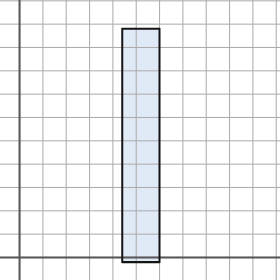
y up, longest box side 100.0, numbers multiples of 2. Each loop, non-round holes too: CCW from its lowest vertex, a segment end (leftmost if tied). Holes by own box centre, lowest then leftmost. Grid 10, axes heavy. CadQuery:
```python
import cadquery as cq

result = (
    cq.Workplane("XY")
    .moveTo(44.0, -2.0)
    .lineTo(60.0, -2.0)
    .lineTo(60.0, 98.0)
    .lineTo(44.0, 98.0)
    .close()
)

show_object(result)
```